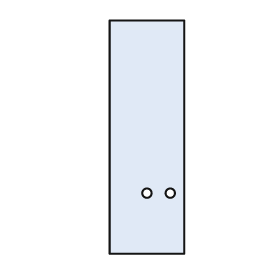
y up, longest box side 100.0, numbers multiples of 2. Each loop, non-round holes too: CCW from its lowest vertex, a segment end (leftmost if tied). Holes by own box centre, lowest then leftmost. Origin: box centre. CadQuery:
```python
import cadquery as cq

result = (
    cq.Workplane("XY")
    .moveTo(-16.0, -50.0)
    .lineTo(16.0, -50.0)
    .lineTo(16.0, 50.0)
    .lineTo(-16.0, 50.0)
    .close()
    .moveTo(0.0, -24.0)
    .circle(2.0)
    .moveTo(10.0, -24.0)
    .circle(2.0)
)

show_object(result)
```